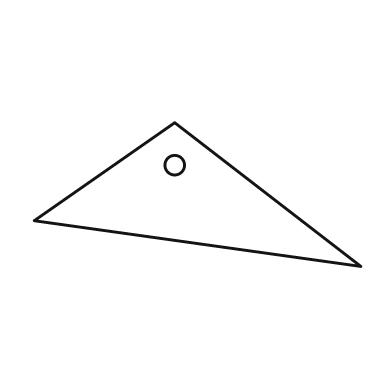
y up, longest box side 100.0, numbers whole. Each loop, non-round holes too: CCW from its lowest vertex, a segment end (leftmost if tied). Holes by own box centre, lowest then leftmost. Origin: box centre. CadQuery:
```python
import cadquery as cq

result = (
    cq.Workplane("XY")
    .moveTo(50.0, -22.0)
    .lineTo(-7.0, 22.0)
    .lineTo(-50.0, -8.0)
    .close()
    .moveTo(-7.0, 9.0)
    .circle(3.0)
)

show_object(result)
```